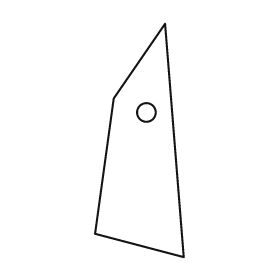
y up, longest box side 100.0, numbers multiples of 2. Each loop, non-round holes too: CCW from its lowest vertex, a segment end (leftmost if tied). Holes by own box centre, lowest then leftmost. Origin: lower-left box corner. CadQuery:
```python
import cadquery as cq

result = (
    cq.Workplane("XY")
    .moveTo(38.0, 0.0)
    .lineTo(30.0, 100.0)
    .lineTo(8.0, 68.0)
    .lineTo(0.0, 10.0)
    .close()
    .moveTo(22.0, 62.0)
    .circle(4.0)
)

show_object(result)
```